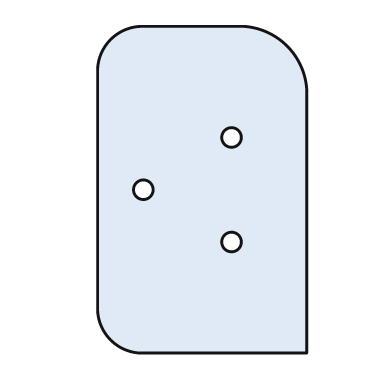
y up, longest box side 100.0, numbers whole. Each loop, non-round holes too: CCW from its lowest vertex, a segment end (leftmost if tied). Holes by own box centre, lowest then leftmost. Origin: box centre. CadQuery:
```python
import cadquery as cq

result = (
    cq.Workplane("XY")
    .moveTo(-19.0, -50.0)
    .lineTo(32.0, -50.0)
    .lineTo(32.0, 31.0)
    .threePointArc((26.0, 44.0), (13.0, 50.0))
    .lineTo(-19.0, 50.0)
    .threePointArc((-28.0, 46.0), (-32.0, 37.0))
    .lineTo(-32.0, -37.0)
    .threePointArc((-28.0, -46.0), (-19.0, -50.0))
    .close()
    .moveTo(9.0, -16.0)
    .circle(3.0)
    .moveTo(-18.0, 0.0)
    .circle(3.0)
    .moveTo(9.0, 16.0)
    .circle(3.0)
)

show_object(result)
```